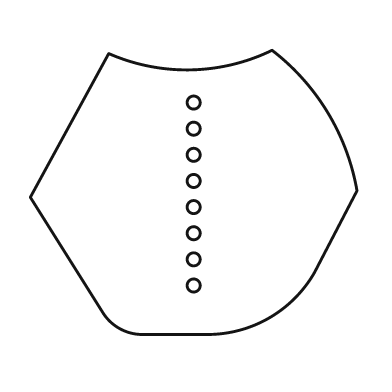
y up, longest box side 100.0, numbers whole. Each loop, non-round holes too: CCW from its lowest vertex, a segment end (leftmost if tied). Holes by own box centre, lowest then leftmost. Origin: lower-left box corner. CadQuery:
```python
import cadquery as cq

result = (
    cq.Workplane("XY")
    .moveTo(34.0, 0.0)
    .lineTo(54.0, 0.0)
    .threePointArc((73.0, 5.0), (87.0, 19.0))
    .lineTo(100.0, 44.0)
    .threePointArc((91.0, 68.0), (74.0, 87.0))
    .threePointArc((49.0, 81.0), (24.0, 86.0))
    .lineTo(0.0, 42.0)
    .lineTo(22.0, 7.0)
    .threePointArc((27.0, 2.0), (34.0, 0.0))
    .close()
    .moveTo(50.0, 15.0)
    .circle(2.0)
    .moveTo(50.0, 23.0)
    .circle(2.0)
    .moveTo(50.0, 31.0)
    .circle(2.0)
    .moveTo(50.0, 39.0)
    .circle(2.0)
    .moveTo(50.0, 47.0)
    .circle(2.0)
    .moveTo(50.0, 55.0)
    .circle(2.0)
    .moveTo(50.0, 63.0)
    .circle(2.0)
    .moveTo(50.0, 71.0)
    .circle(2.0)
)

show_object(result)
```